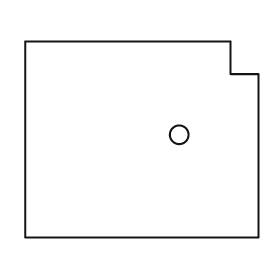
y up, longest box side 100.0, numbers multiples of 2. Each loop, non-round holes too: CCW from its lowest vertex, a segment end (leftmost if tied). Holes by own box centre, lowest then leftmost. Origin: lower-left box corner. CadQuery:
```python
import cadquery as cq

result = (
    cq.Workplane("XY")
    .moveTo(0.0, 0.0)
    .lineTo(100.0, 0.0)
    .lineTo(100.0, 70.0)
    .lineTo(88.0, 70.0)
    .lineTo(88.0, 84.0)
    .lineTo(0.0, 84.0)
    .close()
    .moveTo(66.0, 44.0)
    .circle(4.0)
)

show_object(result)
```